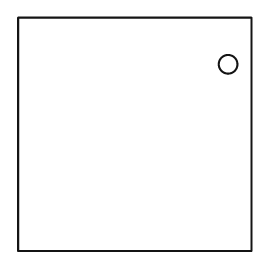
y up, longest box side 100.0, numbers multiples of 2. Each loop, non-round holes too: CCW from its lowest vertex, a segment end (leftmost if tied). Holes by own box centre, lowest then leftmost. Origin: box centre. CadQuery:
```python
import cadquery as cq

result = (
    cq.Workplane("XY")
    .moveTo(-50.0, -50.0)
    .lineTo(50.0, -50.0)
    .lineTo(50.0, 50.0)
    .lineTo(-50.0, 50.0)
    .close()
    .moveTo(40.0, 30.0)
    .circle(4.0)
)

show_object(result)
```